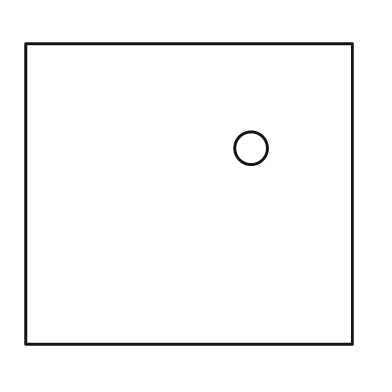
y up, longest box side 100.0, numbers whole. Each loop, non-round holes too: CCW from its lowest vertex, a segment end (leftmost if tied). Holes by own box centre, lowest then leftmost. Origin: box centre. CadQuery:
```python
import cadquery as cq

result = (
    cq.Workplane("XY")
    .moveTo(-50.0, -46.0)
    .lineTo(50.0, -46.0)
    .lineTo(50.0, 46.0)
    .lineTo(-50.0, 46.0)
    .close()
    .moveTo(19.0, 14.0)
    .circle(5.0)
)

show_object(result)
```